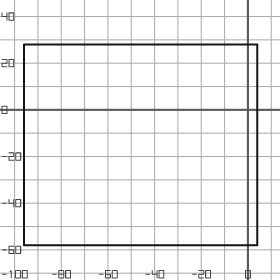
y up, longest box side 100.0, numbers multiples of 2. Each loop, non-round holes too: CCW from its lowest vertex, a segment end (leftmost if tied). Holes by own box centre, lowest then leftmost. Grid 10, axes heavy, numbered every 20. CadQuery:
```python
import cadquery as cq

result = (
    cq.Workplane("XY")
    .moveTo(-96.0, -58.0)
    .lineTo(4.0, -58.0)
    .lineTo(4.0, 28.0)
    .lineTo(-96.0, 28.0)
    .close()
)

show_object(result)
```